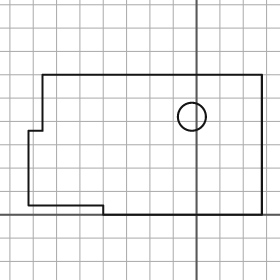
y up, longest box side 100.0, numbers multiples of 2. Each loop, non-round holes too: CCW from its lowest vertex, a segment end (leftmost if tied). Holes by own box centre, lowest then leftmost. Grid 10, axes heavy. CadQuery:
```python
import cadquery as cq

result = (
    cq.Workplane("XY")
    .moveTo(-40.0, 0.0)
    .lineTo(28.0, 0.0)
    .lineTo(28.0, 60.0)
    .lineTo(-66.0, 60.0)
    .lineTo(-66.0, 36.0)
    .lineTo(-72.0, 36.0)
    .lineTo(-72.0, 4.0)
    .lineTo(-40.0, 4.0)
    .close()
    .moveTo(-2.0, 42.0)
    .circle(6.0)
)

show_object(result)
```